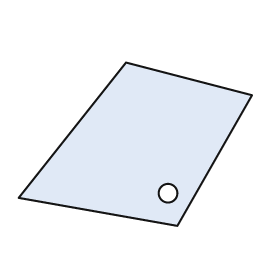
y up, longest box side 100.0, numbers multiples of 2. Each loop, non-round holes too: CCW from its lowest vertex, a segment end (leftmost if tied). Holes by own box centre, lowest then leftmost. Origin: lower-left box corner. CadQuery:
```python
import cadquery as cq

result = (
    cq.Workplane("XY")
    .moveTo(68.0, 0.0)
    .lineTo(100.0, 56.0)
    .lineTo(46.0, 70.0)
    .lineTo(0.0, 12.0)
    .close()
    .moveTo(64.0, 14.0)
    .circle(4.0)
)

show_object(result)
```